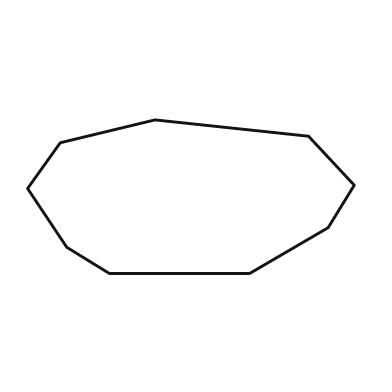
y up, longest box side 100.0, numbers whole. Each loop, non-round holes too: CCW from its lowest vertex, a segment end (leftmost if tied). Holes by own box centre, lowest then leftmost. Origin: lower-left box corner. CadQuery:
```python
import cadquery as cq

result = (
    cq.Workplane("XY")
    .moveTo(25.0, 0.0)
    .lineTo(68.0, 0.0)
    .lineTo(92.0, 14.0)
    .lineTo(100.0, 27.0)
    .lineTo(86.0, 42.0)
    .lineTo(39.0, 47.0)
    .lineTo(10.0, 40.0)
    .lineTo(0.0, 26.0)
    .lineTo(12.0, 8.0)
    .close()
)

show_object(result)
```